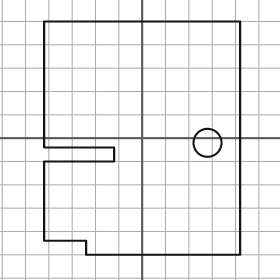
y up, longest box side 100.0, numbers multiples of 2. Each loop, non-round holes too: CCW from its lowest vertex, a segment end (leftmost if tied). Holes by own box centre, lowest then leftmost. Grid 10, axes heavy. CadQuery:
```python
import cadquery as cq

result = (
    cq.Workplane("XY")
    .moveTo(-24.0, -50.0)
    .lineTo(42.0, -50.0)
    .lineTo(42.0, 50.0)
    .lineTo(-42.0, 50.0)
    .lineTo(-42.0, -4.0)
    .lineTo(-12.0, -4.0)
    .lineTo(-12.0, -10.0)
    .lineTo(-42.0, -10.0)
    .lineTo(-42.0, -44.0)
    .lineTo(-24.0, -44.0)
    .close()
    .moveTo(28.0, -2.0)
    .circle(6.0)
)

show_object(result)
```